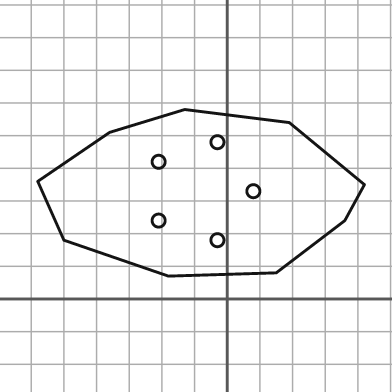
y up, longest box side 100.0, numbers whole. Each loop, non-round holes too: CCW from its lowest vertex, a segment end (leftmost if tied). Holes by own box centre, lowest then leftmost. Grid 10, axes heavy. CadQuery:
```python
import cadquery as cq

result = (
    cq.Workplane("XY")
    .moveTo(-18.0, 7.0)
    .lineTo(15.0, 8.0)
    .lineTo(36.0, 24.0)
    .lineTo(42.0, 35.0)
    .lineTo(19.0, 54.0)
    .lineTo(-13.0, 58.0)
    .lineTo(-36.0, 51.0)
    .lineTo(-58.0, 36.0)
    .lineTo(-50.0, 18.0)
    .close()
    .moveTo(-3.0, 18.0)
    .circle(2.0)
    .moveTo(-21.0, 24.0)
    .circle(2.0)
    .moveTo(8.0, 33.0)
    .circle(2.0)
    .moveTo(-21.0, 42.0)
    .circle(2.0)
    .moveTo(-3.0, 48.0)
    .circle(2.0)
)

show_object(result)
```